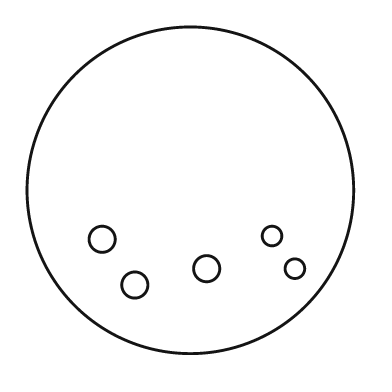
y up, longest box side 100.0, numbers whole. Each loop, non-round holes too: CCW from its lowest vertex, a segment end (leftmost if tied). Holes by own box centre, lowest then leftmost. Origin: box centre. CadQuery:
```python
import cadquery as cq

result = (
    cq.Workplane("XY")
    .moveTo(0.0, 0.0)
    .circle(50.0)
    .moveTo(-17.0, -29.0)
    .circle(4.0)
    .moveTo(5.0, -24.0)
    .circle(4.0)
    .moveTo(32.0, -24.0)
    .circle(3.0)
    .moveTo(-27.0, -15.0)
    .circle(4.0)
    .moveTo(25.0, -14.0)
    .circle(3.0)
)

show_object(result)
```